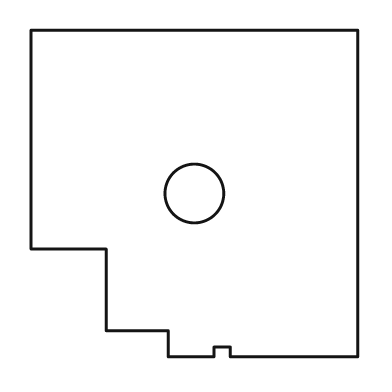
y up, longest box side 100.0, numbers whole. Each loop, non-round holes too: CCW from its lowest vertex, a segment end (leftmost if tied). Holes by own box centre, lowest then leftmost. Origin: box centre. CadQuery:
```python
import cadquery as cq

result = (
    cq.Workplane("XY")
    .moveTo(-8.0, -50.0)
    .lineTo(6.0, -50.0)
    .lineTo(6.0, -47.0)
    .lineTo(11.0, -47.0)
    .lineTo(11.0, -50.0)
    .lineTo(50.0, -50.0)
    .lineTo(50.0, 50.0)
    .lineTo(-50.0, 50.0)
    .lineTo(-50.0, -17.0)
    .lineTo(-27.0, -17.0)
    .lineTo(-27.0, -42.0)
    .lineTo(-8.0, -42.0)
    .close()
    .moveTo(0.0, 0.0)
    .circle(9.0)
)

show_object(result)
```